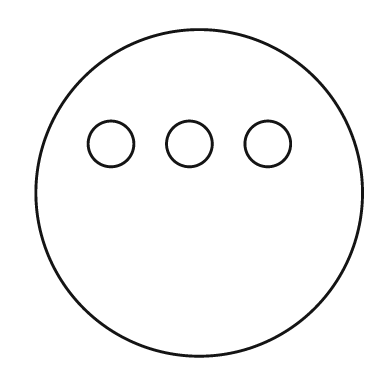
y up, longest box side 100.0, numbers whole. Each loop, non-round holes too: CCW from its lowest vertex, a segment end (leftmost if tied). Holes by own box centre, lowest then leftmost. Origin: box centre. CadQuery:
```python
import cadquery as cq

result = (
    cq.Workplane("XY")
    .moveTo(0.0, 0.0)
    .circle(50.0)
    .moveTo(-27.0, 15.0)
    .circle(7.0)
    .moveTo(-3.0, 15.0)
    .circle(7.0)
    .moveTo(21.0, 15.0)
    .circle(7.0)
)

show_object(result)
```